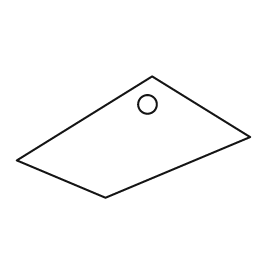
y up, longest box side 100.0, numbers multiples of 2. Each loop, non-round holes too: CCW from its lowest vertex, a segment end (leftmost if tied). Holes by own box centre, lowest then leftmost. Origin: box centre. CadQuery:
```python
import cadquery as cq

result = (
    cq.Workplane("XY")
    .moveTo(-12.0, -26.0)
    .lineTo(50.0, 0.0)
    .lineTo(8.0, 26.0)
    .lineTo(-50.0, -10.0)
    .close()
    .moveTo(6.0, 14.0)
    .circle(4.0)
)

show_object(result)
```